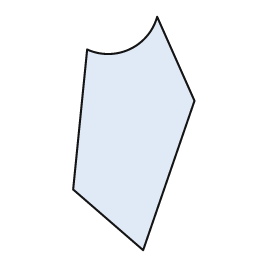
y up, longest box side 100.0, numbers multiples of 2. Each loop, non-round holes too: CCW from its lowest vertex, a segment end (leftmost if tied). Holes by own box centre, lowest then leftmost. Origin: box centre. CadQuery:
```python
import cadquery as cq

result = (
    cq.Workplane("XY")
    .moveTo(4.0, -50.0)
    .lineTo(26.0, 14.0)
    .lineTo(10.0, 50.0)
    .threePointArc((-2.0, 36.0), (-20.0, 36.0))
    .lineTo(-26.0, -24.0)
    .close()
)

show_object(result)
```